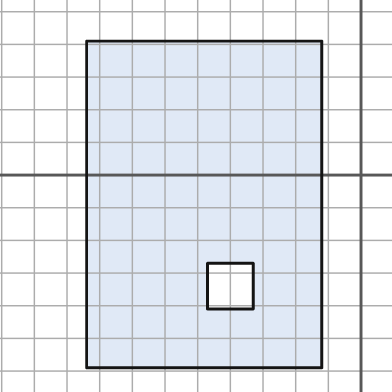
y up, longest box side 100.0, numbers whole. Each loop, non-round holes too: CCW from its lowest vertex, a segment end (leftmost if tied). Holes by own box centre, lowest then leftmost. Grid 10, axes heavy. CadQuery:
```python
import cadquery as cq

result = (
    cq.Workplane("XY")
    .moveTo(-84.0, -59.0)
    .lineTo(-12.0, -59.0)
    .lineTo(-12.0, 41.0)
    .lineTo(-84.0, 41.0)
    .close()
    .moveTo(-47.0, -41.0)
    .lineTo(-33.0, -41.0)
    .lineTo(-33.0, -27.0)
    .lineTo(-47.0, -27.0)
    .close()
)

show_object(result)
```